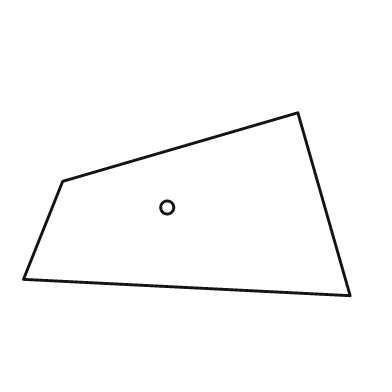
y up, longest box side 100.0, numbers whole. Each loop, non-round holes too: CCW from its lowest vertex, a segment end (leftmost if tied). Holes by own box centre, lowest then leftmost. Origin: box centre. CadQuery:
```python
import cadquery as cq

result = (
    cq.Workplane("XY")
    .moveTo(50.0, -28.0)
    .lineTo(34.0, 28.0)
    .lineTo(-38.0, 7.0)
    .lineTo(-50.0, -23.0)
    .close()
    .moveTo(-6.0, -1.0)
    .circle(2.0)
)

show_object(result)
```